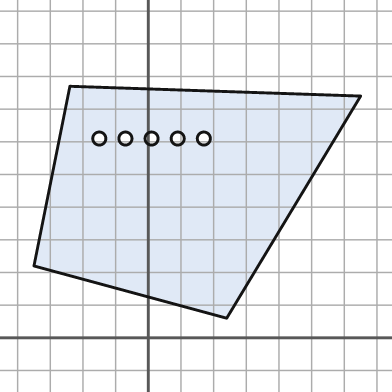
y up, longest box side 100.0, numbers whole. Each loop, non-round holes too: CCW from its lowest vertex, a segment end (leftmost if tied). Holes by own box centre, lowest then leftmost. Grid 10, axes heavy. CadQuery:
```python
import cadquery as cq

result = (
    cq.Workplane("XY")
    .moveTo(24.0, 6.0)
    .lineTo(65.0, 74.0)
    .lineTo(-24.0, 77.0)
    .lineTo(-35.0, 22.0)
    .close()
    .moveTo(-15.0, 61.0)
    .circle(2.0)
    .moveTo(-7.0, 61.0)
    .circle(2.0)
    .moveTo(1.0, 61.0)
    .circle(2.0)
    .moveTo(9.0, 61.0)
    .circle(2.0)
    .moveTo(17.0, 61.0)
    .circle(2.0)
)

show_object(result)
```